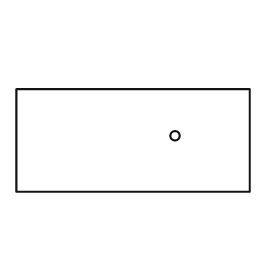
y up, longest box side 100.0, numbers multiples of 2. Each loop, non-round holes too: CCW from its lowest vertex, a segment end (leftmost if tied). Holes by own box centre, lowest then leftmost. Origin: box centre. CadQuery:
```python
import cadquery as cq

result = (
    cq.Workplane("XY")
    .moveTo(-50.0, -22.0)
    .lineTo(50.0, -22.0)
    .lineTo(50.0, 22.0)
    .lineTo(-50.0, 22.0)
    .close()
    .moveTo(18.0, 2.0)
    .circle(2.0)
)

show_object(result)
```